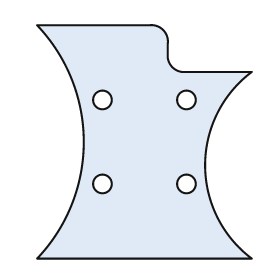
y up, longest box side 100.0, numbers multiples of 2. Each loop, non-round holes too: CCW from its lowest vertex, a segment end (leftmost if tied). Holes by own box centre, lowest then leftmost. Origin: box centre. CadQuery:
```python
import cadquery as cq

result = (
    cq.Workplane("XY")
    .moveTo(-46.0, -50.0)
    .lineTo(46.0, -50.0)
    .threePointArc((26.0, -10.0), (46.0, 30.0))
    .lineTo(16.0, 30.0)
    .threePointArc((12.0, 32.0), (10.0, 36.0))
    .lineTo(10.0, 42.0)
    .threePointArc((8.0, 48.0), (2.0, 50.0))
    .lineTo(-46.0, 50.0)
    .threePointArc((-26.0, 0.0), (-46.0, -50.0))
    .close()
    .moveTo(-18.0, -18.0)
    .circle(4.0)
    .moveTo(18.0, -18.0)
    .circle(4.0)
    .moveTo(-18.0, 18.0)
    .circle(4.0)
    .moveTo(18.0, 18.0)
    .circle(4.0)
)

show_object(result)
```